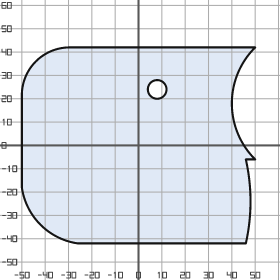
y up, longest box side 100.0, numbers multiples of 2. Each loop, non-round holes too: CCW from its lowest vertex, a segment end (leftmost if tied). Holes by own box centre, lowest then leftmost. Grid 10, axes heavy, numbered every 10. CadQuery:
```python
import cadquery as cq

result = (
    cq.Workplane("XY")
    .moveTo(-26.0, -42.0)
    .lineTo(46.0, -42.0)
    .threePointArc((48.0, -24.0), (46.0, -6.0))
    .lineTo(50.0, -6.0)
    .threePointArc((40.0, 18.0), (50.0, 42.0))
    .lineTo(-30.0, 42.0)
    .threePointArc((-44.0, 36.0), (-50.0, 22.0))
    .lineTo(-50.0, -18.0)
    .threePointArc((-42.0, -34.0), (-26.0, -42.0))
    .close()
    .moveTo(8.0, 24.0)
    .circle(4.0)
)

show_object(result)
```